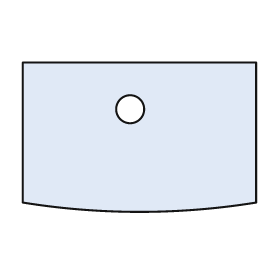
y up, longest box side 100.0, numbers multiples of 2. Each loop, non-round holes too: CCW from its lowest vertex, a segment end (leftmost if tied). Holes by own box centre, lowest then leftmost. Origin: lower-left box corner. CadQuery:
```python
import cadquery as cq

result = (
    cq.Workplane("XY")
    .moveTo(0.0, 4.0)
    .threePointArc((50.0, 0.0), (100.0, 4.0))
    .lineTo(100.0, 64.0)
    .lineTo(0.0, 64.0)
    .close()
    .moveTo(46.0, 44.0)
    .circle(6.0)
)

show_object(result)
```